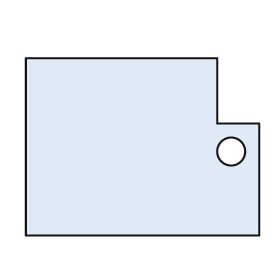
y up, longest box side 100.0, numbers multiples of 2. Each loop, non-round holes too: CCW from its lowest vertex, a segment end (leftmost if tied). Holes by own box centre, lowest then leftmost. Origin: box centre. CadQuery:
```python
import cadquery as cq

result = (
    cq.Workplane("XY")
    .moveTo(-50.0, -38.0)
    .lineTo(50.0, -38.0)
    .lineTo(50.0, 10.0)
    .lineTo(32.0, 10.0)
    .lineTo(32.0, 38.0)
    .lineTo(-50.0, 38.0)
    .close()
    .moveTo(38.0, -2.0)
    .circle(6.0)
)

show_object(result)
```